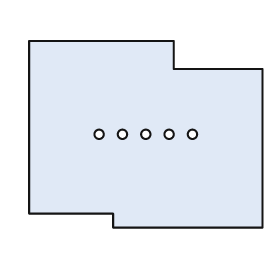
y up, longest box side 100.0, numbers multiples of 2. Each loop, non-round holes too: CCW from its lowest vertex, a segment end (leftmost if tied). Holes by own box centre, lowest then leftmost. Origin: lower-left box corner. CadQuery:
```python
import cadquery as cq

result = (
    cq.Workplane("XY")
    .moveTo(36.0, 0.0)
    .lineTo(100.0, 0.0)
    .lineTo(100.0, 68.0)
    .lineTo(62.0, 68.0)
    .lineTo(62.0, 80.0)
    .lineTo(0.0, 80.0)
    .lineTo(0.0, 6.0)
    .lineTo(36.0, 6.0)
    .close()
    .moveTo(30.0, 40.0)
    .circle(2.0)
    .moveTo(40.0, 40.0)
    .circle(2.0)
    .moveTo(50.0, 40.0)
    .circle(2.0)
    .moveTo(60.0, 40.0)
    .circle(2.0)
    .moveTo(70.0, 40.0)
    .circle(2.0)
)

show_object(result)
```